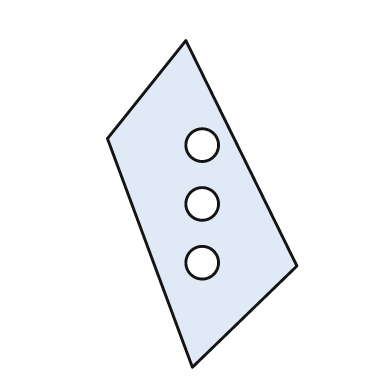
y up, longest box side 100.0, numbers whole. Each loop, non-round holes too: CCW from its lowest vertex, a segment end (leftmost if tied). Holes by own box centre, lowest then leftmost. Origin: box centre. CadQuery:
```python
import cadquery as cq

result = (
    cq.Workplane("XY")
    .moveTo(-3.0, -50.0)
    .lineTo(29.0, -19.0)
    .lineTo(-5.0, 50.0)
    .lineTo(-29.0, 20.0)
    .close()
    .moveTo(0.0, -18.0)
    .circle(5.0)
    .moveTo(0.0, 0.0)
    .circle(5.0)
    .moveTo(0.0, 18.0)
    .circle(5.0)
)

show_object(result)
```